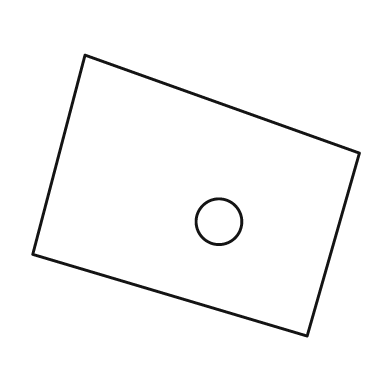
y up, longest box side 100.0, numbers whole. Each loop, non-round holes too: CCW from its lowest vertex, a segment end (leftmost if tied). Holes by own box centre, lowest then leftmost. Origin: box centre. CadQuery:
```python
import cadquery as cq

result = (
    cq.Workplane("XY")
    .moveTo(34.0, -43.0)
    .lineTo(50.0, 13.0)
    .lineTo(-34.0, 43.0)
    .lineTo(-50.0, -18.0)
    .close()
    .moveTo(7.0, -8.0)
    .circle(7.0)
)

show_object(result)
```